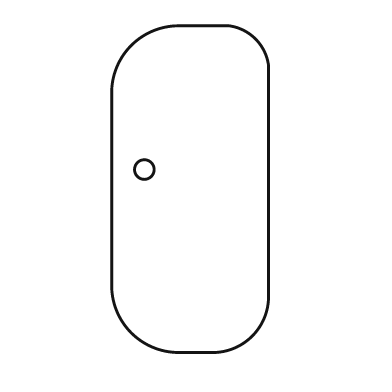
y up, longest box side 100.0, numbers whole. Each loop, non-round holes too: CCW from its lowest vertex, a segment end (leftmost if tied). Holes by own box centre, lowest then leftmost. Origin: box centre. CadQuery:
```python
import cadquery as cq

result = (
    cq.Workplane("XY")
    .moveTo(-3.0, -50.0)
    .lineTo(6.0, -50.0)
    .threePointArc((19.0, -45.0), (24.0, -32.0))
    .lineTo(24.0, 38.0)
    .threePointArc((20.0, 46.0), (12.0, 50.0))
    .lineTo(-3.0, 50.0)
    .threePointArc((-18.0, 44.0), (-24.0, 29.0))
    .lineTo(-24.0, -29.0)
    .threePointArc((-18.0, -44.0), (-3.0, -50.0))
    .close()
    .moveTo(-14.0, 6.0)
    .circle(3.0)
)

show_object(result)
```